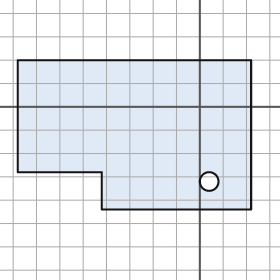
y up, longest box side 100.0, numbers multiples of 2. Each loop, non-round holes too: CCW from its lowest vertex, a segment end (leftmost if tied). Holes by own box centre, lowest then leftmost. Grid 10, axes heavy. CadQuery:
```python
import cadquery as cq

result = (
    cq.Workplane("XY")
    .moveTo(-42.0, -44.0)
    .lineTo(22.0, -44.0)
    .lineTo(22.0, 20.0)
    .lineTo(-78.0, 20.0)
    .lineTo(-78.0, -28.0)
    .lineTo(-42.0, -28.0)
    .close()
    .moveTo(4.0, -32.0)
    .circle(4.0)
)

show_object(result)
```